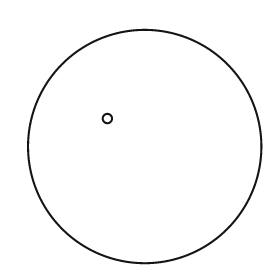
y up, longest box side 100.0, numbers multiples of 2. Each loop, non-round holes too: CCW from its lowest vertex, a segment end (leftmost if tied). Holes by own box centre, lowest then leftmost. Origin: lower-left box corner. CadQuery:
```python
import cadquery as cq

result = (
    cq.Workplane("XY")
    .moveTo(50.0, 50.0)
    .circle(50.0)
    .moveTo(34.0, 62.0)
    .circle(2.0)
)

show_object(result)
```